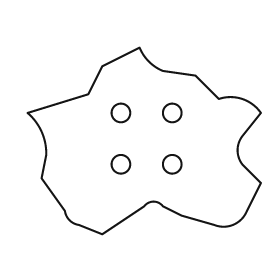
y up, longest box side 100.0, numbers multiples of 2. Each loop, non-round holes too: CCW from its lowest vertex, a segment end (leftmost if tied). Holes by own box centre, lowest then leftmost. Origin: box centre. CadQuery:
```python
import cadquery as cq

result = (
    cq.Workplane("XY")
    .moveTo(-18.0, -40.0)
    .lineTo(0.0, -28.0)
    .threePointArc((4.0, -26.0), (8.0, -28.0))
    .lineTo(16.0, -32.0)
    .lineTo(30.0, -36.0)
    .threePointArc((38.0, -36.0), (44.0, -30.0))
    .lineTo(50.0, -18.0)
    .lineTo(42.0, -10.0)
    .threePointArc((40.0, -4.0), (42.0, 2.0))
    .lineTo(50.0, 12.0)
    .threePointArc((42.0, 18.0), (32.0, 18.0))
    .lineTo(22.0, 28.0)
    .lineTo(8.0, 30.0)
    .threePointArc((2.0, 34.0), (-2.0, 40.0))
    .lineTo(-18.0, 32.0)
    .lineTo(-24.0, 20.0)
    .lineTo(-50.0, 12.0)
    .threePointArc((-44.0, 4.0), (-42.0, -6.0))
    .lineTo(-44.0, -16.0)
    .lineTo(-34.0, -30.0)
    .threePointArc((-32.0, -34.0), (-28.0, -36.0))
    .close()
    .moveTo(-10.0, -10.0)
    .circle(4.0)
    .moveTo(12.0, -10.0)
    .circle(4.0)
    .moveTo(-10.0, 12.0)
    .circle(4.0)
    .moveTo(12.0, 12.0)
    .circle(4.0)
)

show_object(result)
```